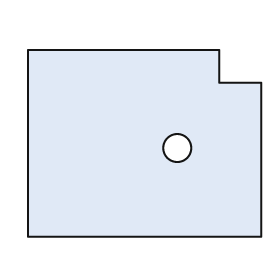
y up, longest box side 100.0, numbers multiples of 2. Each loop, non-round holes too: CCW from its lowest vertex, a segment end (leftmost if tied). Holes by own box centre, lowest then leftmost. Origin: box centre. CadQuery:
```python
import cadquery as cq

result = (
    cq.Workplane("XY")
    .moveTo(-50.0, -40.0)
    .lineTo(50.0, -40.0)
    .lineTo(50.0, 26.0)
    .lineTo(32.0, 26.0)
    .lineTo(32.0, 40.0)
    .lineTo(-50.0, 40.0)
    .close()
    .moveTo(14.0, -2.0)
    .circle(6.0)
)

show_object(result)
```